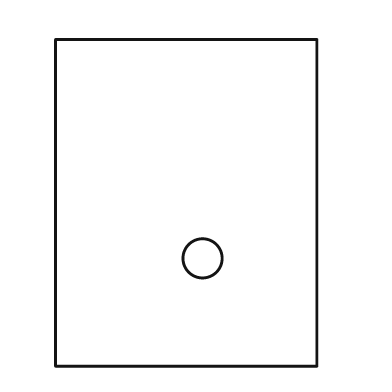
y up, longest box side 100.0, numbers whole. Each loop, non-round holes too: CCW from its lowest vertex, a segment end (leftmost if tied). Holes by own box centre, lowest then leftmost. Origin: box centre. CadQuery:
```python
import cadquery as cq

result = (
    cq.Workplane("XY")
    .moveTo(-40.0, -50.0)
    .lineTo(40.0, -50.0)
    .lineTo(40.0, 50.0)
    .lineTo(-40.0, 50.0)
    .close()
    .moveTo(5.0, -17.0)
    .circle(6.0)
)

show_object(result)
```